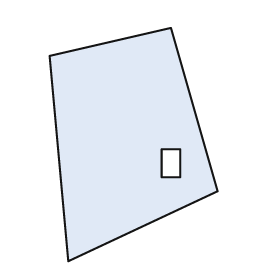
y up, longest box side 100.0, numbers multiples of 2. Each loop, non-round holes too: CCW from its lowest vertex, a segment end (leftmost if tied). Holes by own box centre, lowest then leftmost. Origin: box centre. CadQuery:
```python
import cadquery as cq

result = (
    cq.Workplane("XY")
    .moveTo(-28.0, -50.0)
    .lineTo(36.0, -20.0)
    .lineTo(16.0, 50.0)
    .lineTo(-36.0, 38.0)
    .close()
    .moveTo(12.0, -14.0)
    .lineTo(20.0, -14.0)
    .lineTo(20.0, -2.0)
    .lineTo(12.0, -2.0)
    .close()
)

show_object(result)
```